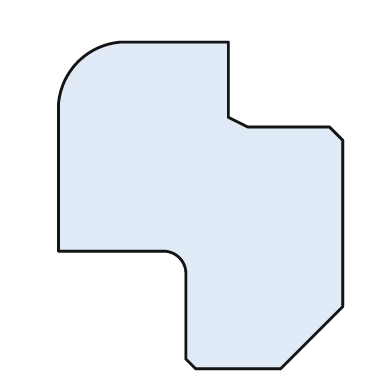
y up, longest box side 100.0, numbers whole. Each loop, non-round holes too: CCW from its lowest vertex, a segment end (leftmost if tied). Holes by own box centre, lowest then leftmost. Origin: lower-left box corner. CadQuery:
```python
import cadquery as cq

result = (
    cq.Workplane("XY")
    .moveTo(42.0, 0.0)
    .lineTo(68.0, 0.0)
    .lineTo(87.0, 19.0)
    .lineTo(87.0, 70.0)
    .lineTo(83.0, 74.0)
    .lineTo(58.0, 74.0)
    .lineTo(52.0, 77.0)
    .lineTo(52.0, 100.0)
    .lineTo(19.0, 100.0)
    .threePointArc((6.0, 94.0), (0.0, 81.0))
    .lineTo(0.0, 36.0)
    .lineTo(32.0, 36.0)
    .threePointArc((37.0, 34.0), (39.0, 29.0))
    .lineTo(39.0, 3.0)
    .close()
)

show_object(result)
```